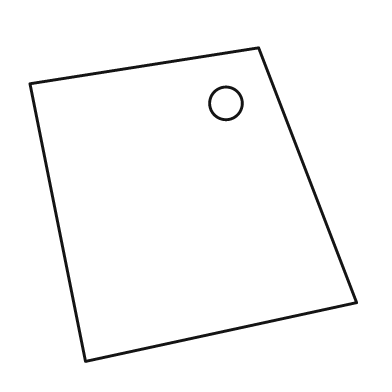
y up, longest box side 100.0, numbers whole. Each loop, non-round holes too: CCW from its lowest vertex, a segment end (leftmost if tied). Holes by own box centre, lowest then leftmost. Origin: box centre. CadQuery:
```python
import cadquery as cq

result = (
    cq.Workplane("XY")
    .moveTo(-33.0, -48.0)
    .lineTo(50.0, -30.0)
    .lineTo(20.0, 48.0)
    .lineTo(-50.0, 37.0)
    .close()
    .moveTo(10.0, 31.0)
    .circle(5.0)
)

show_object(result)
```